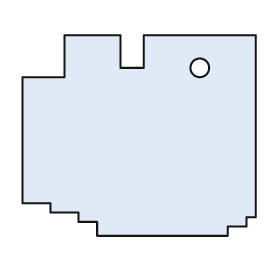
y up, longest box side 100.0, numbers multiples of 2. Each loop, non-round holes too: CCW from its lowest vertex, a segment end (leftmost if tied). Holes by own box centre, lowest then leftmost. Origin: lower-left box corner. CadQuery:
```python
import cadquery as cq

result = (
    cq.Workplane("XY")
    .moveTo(32.0, 0.0)
    .lineTo(88.0, 0.0)
    .lineTo(88.0, 4.0)
    .lineTo(96.0, 4.0)
    .lineTo(96.0, 8.0)
    .lineTo(100.0, 8.0)
    .lineTo(100.0, 86.0)
    .lineTo(52.0, 86.0)
    .lineTo(52.0, 72.0)
    .lineTo(42.0, 72.0)
    .lineTo(42.0, 86.0)
    .lineTo(18.0, 86.0)
    .lineTo(18.0, 68.0)
    .lineTo(0.0, 68.0)
    .lineTo(0.0, 14.0)
    .lineTo(12.0, 14.0)
    .lineTo(12.0, 10.0)
    .lineTo(24.0, 10.0)
    .lineTo(24.0, 6.0)
    .lineTo(32.0, 6.0)
    .close()
    .moveTo(76.0, 72.0)
    .circle(4.0)
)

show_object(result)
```